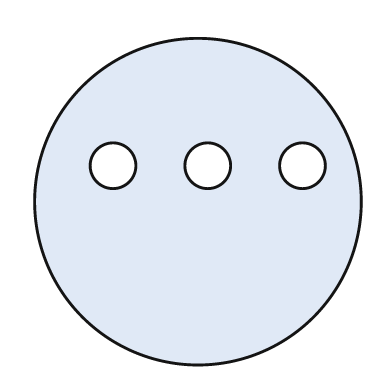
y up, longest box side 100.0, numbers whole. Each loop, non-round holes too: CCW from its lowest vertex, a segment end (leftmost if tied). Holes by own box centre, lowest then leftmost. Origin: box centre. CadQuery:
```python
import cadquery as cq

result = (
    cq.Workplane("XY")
    .moveTo(0.0, 0.0)
    .circle(50.0)
    .moveTo(-26.0, 11.0)
    .circle(7.0)
    .moveTo(3.0, 11.0)
    .circle(7.0)
    .moveTo(32.0, 11.0)
    .circle(7.0)
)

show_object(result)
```